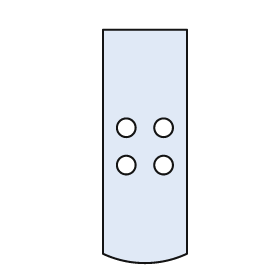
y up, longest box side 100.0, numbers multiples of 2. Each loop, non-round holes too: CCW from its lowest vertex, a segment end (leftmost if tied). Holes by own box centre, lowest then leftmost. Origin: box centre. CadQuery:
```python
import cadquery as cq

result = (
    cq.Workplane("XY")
    .moveTo(-18.0, -46.0)
    .threePointArc((0.0, -50.0), (18.0, -46.0))
    .lineTo(18.0, 50.0)
    .lineTo(-18.0, 50.0)
    .close()
    .moveTo(-8.0, -8.0)
    .circle(4.0)
    .moveTo(8.0, -8.0)
    .circle(4.0)
    .moveTo(-8.0, 8.0)
    .circle(4.0)
    .moveTo(8.0, 8.0)
    .circle(4.0)
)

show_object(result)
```